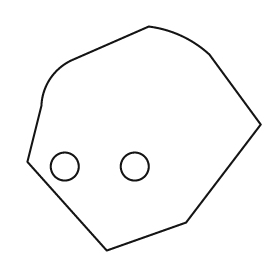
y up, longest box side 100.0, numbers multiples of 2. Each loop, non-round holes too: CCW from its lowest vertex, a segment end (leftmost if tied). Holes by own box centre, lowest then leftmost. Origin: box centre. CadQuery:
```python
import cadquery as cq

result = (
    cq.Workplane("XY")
    .moveTo(-16.0, -48.0)
    .lineTo(18.0, -36.0)
    .lineTo(50.0, 6.0)
    .lineTo(28.0, 36.0)
    .threePointArc((16.0, 44.0), (2.0, 48.0))
    .lineTo(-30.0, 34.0)
    .threePointArc((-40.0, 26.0), (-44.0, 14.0))
    .lineTo(-50.0, -10.0)
    .close()
    .moveTo(-34.0, -12.0)
    .circle(6.0)
    .moveTo(-4.0, -12.0)
    .circle(6.0)
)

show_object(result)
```